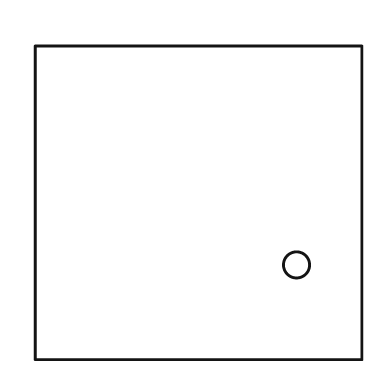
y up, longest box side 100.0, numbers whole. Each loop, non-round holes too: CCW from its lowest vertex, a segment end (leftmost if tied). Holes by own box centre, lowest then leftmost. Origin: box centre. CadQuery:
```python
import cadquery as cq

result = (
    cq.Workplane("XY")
    .moveTo(-50.0, -48.0)
    .lineTo(50.0, -48.0)
    .lineTo(50.0, 48.0)
    .lineTo(-50.0, 48.0)
    .close()
    .moveTo(30.0, -19.0)
    .circle(4.0)
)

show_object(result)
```